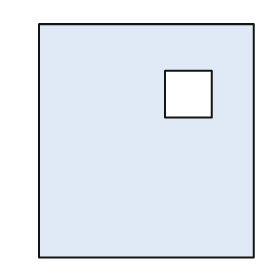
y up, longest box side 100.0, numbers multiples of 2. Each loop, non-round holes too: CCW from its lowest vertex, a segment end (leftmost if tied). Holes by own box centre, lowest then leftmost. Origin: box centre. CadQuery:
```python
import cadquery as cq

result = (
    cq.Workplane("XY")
    .moveTo(-46.0, -50.0)
    .lineTo(46.0, -50.0)
    .lineTo(46.0, 50.0)
    .lineTo(-46.0, 50.0)
    .close()
    .moveTo(8.0, 10.0)
    .lineTo(28.0, 10.0)
    .lineTo(28.0, 30.0)
    .lineTo(8.0, 30.0)
    .close()
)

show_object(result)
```